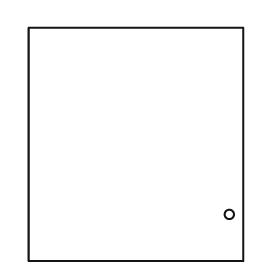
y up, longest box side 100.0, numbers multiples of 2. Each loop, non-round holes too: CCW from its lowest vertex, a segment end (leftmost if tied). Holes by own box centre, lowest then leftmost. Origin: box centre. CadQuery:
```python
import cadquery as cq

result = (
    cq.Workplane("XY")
    .moveTo(-46.0, -50.0)
    .lineTo(46.0, -50.0)
    .lineTo(46.0, 50.0)
    .lineTo(-46.0, 50.0)
    .close()
    .moveTo(40.0, -30.0)
    .circle(2.0)
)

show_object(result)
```